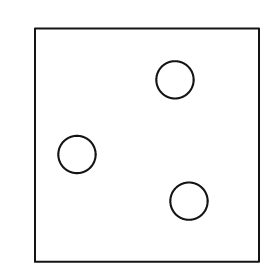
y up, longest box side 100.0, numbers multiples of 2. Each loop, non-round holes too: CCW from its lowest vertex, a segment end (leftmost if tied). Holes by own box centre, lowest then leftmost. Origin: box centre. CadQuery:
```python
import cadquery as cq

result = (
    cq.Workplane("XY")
    .moveTo(-48.0, -50.0)
    .lineTo(48.0, -50.0)
    .lineTo(48.0, 50.0)
    .lineTo(-48.0, 50.0)
    .close()
    .moveTo(18.0, -24.0)
    .circle(8.0)
    .moveTo(-30.0, -4.0)
    .circle(8.0)
    .moveTo(12.0, 28.0)
    .circle(8.0)
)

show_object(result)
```